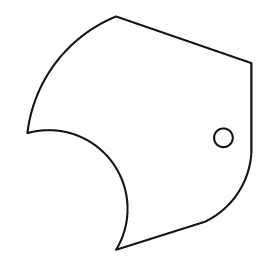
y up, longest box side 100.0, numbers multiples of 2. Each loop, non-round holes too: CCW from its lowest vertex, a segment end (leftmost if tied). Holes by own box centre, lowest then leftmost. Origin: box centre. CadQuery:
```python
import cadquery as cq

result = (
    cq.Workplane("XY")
    .moveTo(-10.0, -50.0)
    .lineTo(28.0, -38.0)
    .threePointArc((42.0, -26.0), (48.0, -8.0))
    .lineTo(48.0, 30.0)
    .lineTo(-10.0, 50.0)
    .threePointArc((-36.0, 30.0), (-48.0, 0.0))
    .threePointArc((-12.0, -12.0), (-10.0, -50.0))
    .close()
    .moveTo(36.0, -2.0)
    .circle(4.0)
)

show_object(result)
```